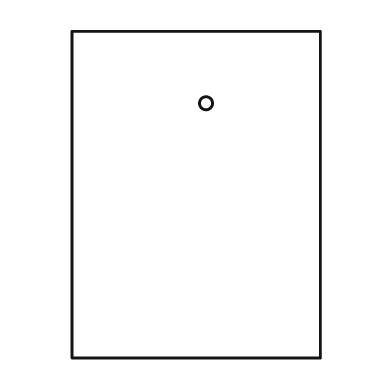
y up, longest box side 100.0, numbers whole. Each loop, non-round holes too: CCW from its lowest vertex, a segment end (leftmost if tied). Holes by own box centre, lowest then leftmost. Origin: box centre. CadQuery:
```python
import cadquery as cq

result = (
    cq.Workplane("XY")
    .moveTo(-38.0, -50.0)
    .lineTo(38.0, -50.0)
    .lineTo(38.0, 50.0)
    .lineTo(-38.0, 50.0)
    .close()
    .moveTo(3.0, 28.0)
    .circle(2.0)
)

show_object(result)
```